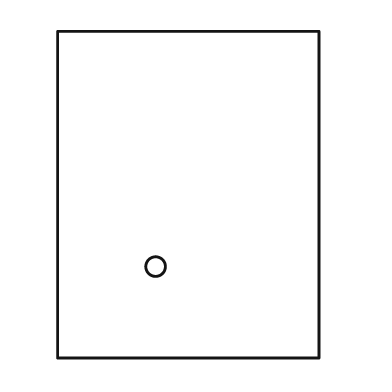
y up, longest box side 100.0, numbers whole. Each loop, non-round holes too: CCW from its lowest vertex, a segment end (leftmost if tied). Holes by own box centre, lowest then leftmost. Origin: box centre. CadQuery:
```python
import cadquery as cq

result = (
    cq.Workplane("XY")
    .moveTo(-40.0, -50.0)
    .lineTo(40.0, -50.0)
    .lineTo(40.0, 50.0)
    .lineTo(-40.0, 50.0)
    .close()
    .moveTo(-10.0, -22.0)
    .circle(3.0)
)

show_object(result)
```